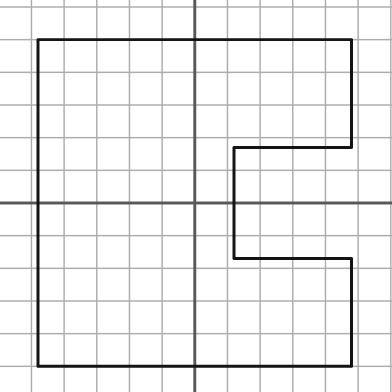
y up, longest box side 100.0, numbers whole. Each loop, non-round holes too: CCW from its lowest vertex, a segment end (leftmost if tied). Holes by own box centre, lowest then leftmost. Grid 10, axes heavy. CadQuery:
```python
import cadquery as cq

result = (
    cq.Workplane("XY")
    .moveTo(-48.0, -50.0)
    .lineTo(48.0, -50.0)
    .lineTo(48.0, -17.0)
    .lineTo(12.0, -17.0)
    .lineTo(12.0, 17.0)
    .lineTo(48.0, 17.0)
    .lineTo(48.0, 50.0)
    .lineTo(-48.0, 50.0)
    .close()
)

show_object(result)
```